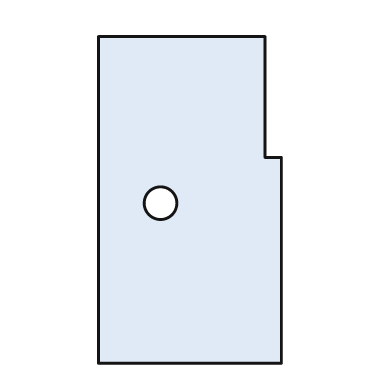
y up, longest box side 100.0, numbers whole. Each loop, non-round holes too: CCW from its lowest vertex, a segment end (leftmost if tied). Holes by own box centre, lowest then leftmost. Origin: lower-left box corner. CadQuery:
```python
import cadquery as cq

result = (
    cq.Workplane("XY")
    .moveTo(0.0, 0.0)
    .lineTo(56.0, 0.0)
    .lineTo(56.0, 63.0)
    .lineTo(51.0, 63.0)
    .lineTo(51.0, 100.0)
    .lineTo(0.0, 100.0)
    .close()
    .moveTo(19.0, 49.0)
    .circle(5.0)
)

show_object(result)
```